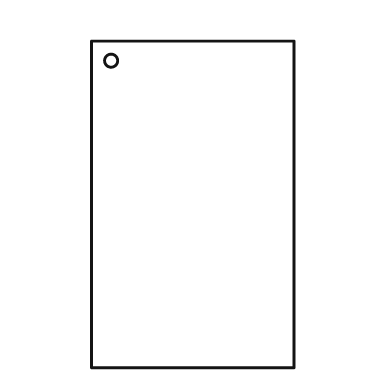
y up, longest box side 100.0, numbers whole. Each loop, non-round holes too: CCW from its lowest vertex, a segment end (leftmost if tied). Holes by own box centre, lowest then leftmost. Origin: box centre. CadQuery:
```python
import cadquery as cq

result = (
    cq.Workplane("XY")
    .moveTo(-31.0, -50.0)
    .lineTo(31.0, -50.0)
    .lineTo(31.0, 50.0)
    .lineTo(-31.0, 50.0)
    .close()
    .moveTo(-25.0, 44.0)
    .circle(2.0)
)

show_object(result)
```